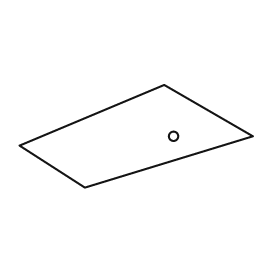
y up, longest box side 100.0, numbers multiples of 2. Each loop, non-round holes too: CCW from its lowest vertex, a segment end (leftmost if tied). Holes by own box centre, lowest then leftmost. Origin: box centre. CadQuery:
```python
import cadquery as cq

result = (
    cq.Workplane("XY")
    .moveTo(-22.0, -22.0)
    .lineTo(50.0, 0.0)
    .lineTo(12.0, 22.0)
    .lineTo(-50.0, -4.0)
    .close()
    .moveTo(16.0, 0.0)
    .circle(2.0)
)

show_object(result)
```